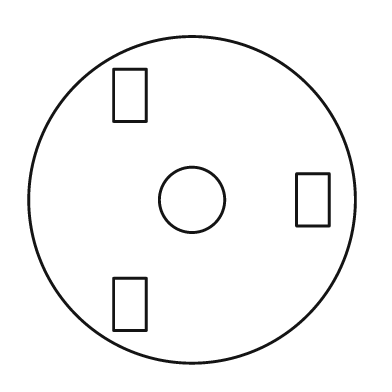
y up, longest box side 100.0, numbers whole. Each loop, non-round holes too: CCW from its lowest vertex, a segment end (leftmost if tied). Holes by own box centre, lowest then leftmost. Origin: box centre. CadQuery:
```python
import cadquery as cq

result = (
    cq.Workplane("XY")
    .moveTo(0.0, 0.0)
    .circle(50.0)
    .moveTo(-24.0, -40.0)
    .lineTo(-14.0, -40.0)
    .lineTo(-14.0, -24.0)
    .lineTo(-24.0, -24.0)
    .close()
    .moveTo(0.0, 0.0)
    .circle(10.0)
    .moveTo(32.0, -8.0)
    .lineTo(42.0, -8.0)
    .lineTo(42.0, 8.0)
    .lineTo(32.0, 8.0)
    .close()
    .moveTo(-24.0, 24.0)
    .lineTo(-14.0, 24.0)
    .lineTo(-14.0, 40.0)
    .lineTo(-24.0, 40.0)
    .close()
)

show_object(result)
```